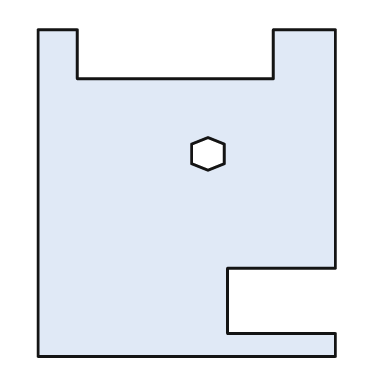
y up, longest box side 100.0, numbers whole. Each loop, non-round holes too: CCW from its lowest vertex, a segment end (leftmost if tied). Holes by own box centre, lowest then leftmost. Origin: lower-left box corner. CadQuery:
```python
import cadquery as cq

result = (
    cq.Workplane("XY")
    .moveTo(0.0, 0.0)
    .lineTo(91.0, 0.0)
    .lineTo(91.0, 7.0)
    .lineTo(58.0, 7.0)
    .lineTo(58.0, 27.0)
    .lineTo(91.0, 27.0)
    .lineTo(91.0, 100.0)
    .lineTo(72.0, 100.0)
    .lineTo(72.0, 85.0)
    .lineTo(12.0, 85.0)
    .lineTo(12.0, 100.0)
    .lineTo(0.0, 100.0)
    .close()
    .moveTo(52.0, 57.0)
    .lineTo(57.0, 59.0)
    .lineTo(57.0, 65.0)
    .lineTo(52.0, 67.0)
    .lineTo(47.0, 65.0)
    .lineTo(47.0, 59.0)
    .close()
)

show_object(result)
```